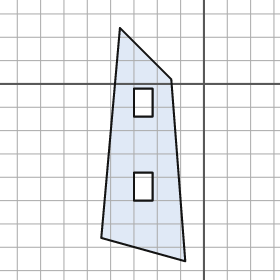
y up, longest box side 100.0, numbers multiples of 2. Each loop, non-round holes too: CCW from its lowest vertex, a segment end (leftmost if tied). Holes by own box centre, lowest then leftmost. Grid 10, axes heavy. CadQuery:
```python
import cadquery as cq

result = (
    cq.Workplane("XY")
    .moveTo(-8.0, -76.0)
    .lineTo(-14.0, 2.0)
    .lineTo(-36.0, 24.0)
    .lineTo(-44.0, -66.0)
    .close()
    .moveTo(-30.0, -50.0)
    .lineTo(-22.0, -50.0)
    .lineTo(-22.0, -38.0)
    .lineTo(-30.0, -38.0)
    .close()
    .moveTo(-30.0, -14.0)
    .lineTo(-22.0, -14.0)
    .lineTo(-22.0, -2.0)
    .lineTo(-30.0, -2.0)
    .close()
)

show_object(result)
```